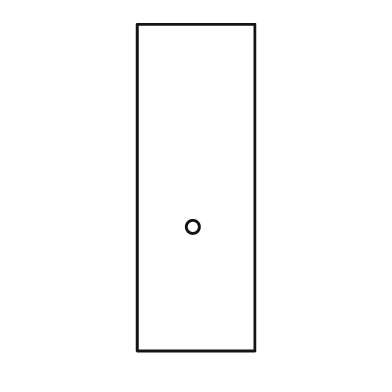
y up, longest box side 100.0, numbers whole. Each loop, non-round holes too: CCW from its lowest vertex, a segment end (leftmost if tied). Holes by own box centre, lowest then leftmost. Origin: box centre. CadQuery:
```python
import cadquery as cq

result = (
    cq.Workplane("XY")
    .moveTo(-18.0, -50.0)
    .lineTo(18.0, -50.0)
    .lineTo(18.0, 50.0)
    .lineTo(-18.0, 50.0)
    .close()
    .moveTo(-1.0, -12.0)
    .circle(2.0)
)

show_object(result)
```